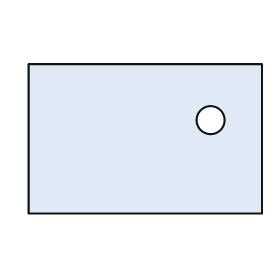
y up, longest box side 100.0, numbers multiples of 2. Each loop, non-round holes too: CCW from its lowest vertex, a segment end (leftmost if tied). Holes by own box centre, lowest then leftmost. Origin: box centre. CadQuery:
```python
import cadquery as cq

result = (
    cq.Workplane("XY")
    .moveTo(-50.0, -32.0)
    .lineTo(50.0, -32.0)
    .lineTo(50.0, 32.0)
    .lineTo(-50.0, 32.0)
    .close()
    .moveTo(28.0, 8.0)
    .circle(6.0)
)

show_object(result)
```